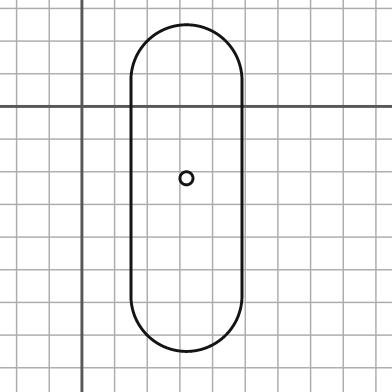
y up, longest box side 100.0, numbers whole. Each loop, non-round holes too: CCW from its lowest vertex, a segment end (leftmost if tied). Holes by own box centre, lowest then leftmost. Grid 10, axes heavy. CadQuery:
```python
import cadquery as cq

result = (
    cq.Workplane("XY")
    .moveTo(15.0, -58.0)
    .threePointArc((32.0, -75.0), (49.0, -58.0))
    .lineTo(49.0, 8.0)
    .threePointArc((32.0, 25.0), (15.0, 8.0))
    .close()
    .moveTo(32.0, -22.0)
    .circle(2.0)
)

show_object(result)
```